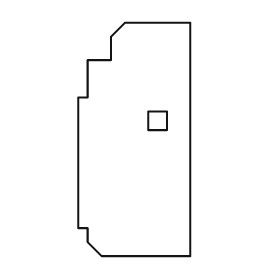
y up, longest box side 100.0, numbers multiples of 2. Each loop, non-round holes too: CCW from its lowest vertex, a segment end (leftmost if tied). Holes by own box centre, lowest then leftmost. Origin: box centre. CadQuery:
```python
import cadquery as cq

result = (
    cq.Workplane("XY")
    .moveTo(-14.0, -50.0)
    .lineTo(24.0, -50.0)
    .lineTo(24.0, 50.0)
    .lineTo(-4.0, 50.0)
    .lineTo(-10.0, 44.0)
    .lineTo(-10.0, 34.0)
    .lineTo(-20.0, 34.0)
    .lineTo(-20.0, 18.0)
    .lineTo(-24.0, 18.0)
    .lineTo(-24.0, -38.0)
    .lineTo(-20.0, -38.0)
    .lineTo(-20.0, -44.0)
    .close()
    .moveTo(6.0, 4.0)
    .lineTo(14.0, 4.0)
    .lineTo(14.0, 12.0)
    .lineTo(6.0, 12.0)
    .close()
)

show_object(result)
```